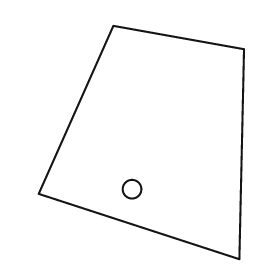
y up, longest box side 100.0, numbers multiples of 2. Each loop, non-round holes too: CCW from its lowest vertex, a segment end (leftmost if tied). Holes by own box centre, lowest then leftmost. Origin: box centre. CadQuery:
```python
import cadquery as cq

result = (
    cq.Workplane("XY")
    .moveTo(42.0, -50.0)
    .lineTo(44.0, 40.0)
    .lineTo(-12.0, 50.0)
    .lineTo(-44.0, -22.0)
    .close()
    .moveTo(-4.0, -20.0)
    .circle(4.0)
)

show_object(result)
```